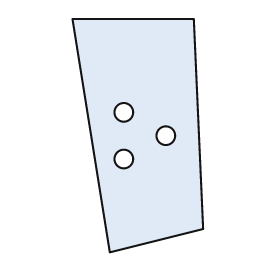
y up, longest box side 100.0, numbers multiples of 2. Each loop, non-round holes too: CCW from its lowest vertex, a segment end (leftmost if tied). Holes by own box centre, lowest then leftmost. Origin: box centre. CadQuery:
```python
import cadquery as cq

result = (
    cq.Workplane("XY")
    .moveTo(-12.0, -50.0)
    .lineTo(28.0, -40.0)
    .lineTo(24.0, 50.0)
    .lineTo(-28.0, 50.0)
    .close()
    .moveTo(-6.0, -10.0)
    .circle(4.0)
    .moveTo(12.0, 0.0)
    .circle(4.0)
    .moveTo(-6.0, 10.0)
    .circle(4.0)
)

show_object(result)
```